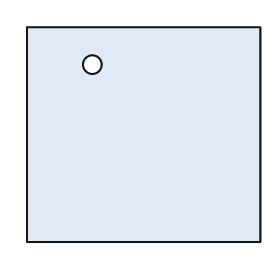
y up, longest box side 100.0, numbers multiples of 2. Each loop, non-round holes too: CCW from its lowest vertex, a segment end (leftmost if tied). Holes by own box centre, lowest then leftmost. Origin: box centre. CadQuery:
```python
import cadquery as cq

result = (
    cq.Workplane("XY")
    .moveTo(-50.0, -46.0)
    .lineTo(50.0, -46.0)
    .lineTo(50.0, 46.0)
    .lineTo(-50.0, 46.0)
    .close()
    .moveTo(-22.0, 30.0)
    .circle(4.0)
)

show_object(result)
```